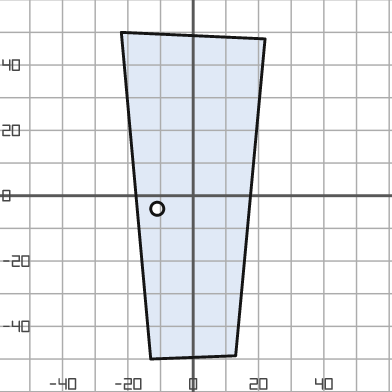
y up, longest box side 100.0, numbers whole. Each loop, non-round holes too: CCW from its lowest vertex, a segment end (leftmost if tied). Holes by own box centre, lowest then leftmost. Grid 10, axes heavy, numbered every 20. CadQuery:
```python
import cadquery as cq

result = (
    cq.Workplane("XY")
    .moveTo(-13.0, -50.0)
    .lineTo(13.0, -49.0)
    .lineTo(22.0, 48.0)
    .lineTo(-22.0, 50.0)
    .close()
    .moveTo(-11.0, -4.0)
    .circle(2.0)
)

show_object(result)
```